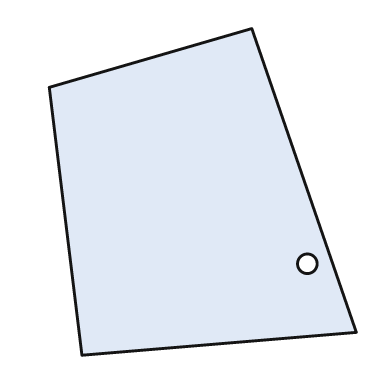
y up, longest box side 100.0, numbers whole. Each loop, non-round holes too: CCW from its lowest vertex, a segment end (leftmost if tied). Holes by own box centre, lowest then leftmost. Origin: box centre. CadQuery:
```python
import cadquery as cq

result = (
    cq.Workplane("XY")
    .moveTo(-37.0, -50.0)
    .lineTo(47.0, -43.0)
    .lineTo(15.0, 50.0)
    .lineTo(-47.0, 32.0)
    .close()
    .moveTo(32.0, -22.0)
    .circle(3.0)
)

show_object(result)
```